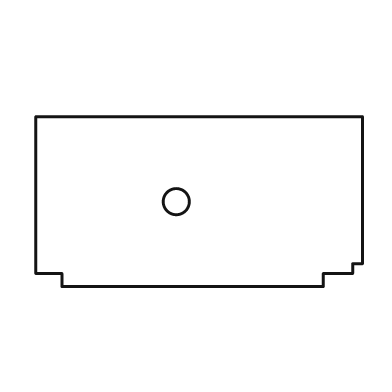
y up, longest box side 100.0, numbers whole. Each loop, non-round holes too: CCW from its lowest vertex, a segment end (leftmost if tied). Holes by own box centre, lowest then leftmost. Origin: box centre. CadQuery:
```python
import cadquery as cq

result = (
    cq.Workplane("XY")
    .moveTo(-42.0, -26.0)
    .lineTo(38.0, -26.0)
    .lineTo(38.0, -22.0)
    .lineTo(47.0, -22.0)
    .lineTo(47.0, -19.0)
    .lineTo(50.0, -19.0)
    .lineTo(50.0, 26.0)
    .lineTo(-50.0, 26.0)
    .lineTo(-50.0, -22.0)
    .lineTo(-42.0, -22.0)
    .close()
    .moveTo(-7.0, 0.0)
    .circle(4.0)
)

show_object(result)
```